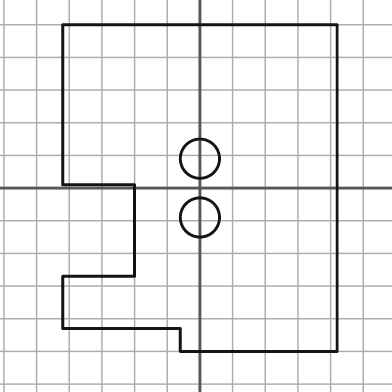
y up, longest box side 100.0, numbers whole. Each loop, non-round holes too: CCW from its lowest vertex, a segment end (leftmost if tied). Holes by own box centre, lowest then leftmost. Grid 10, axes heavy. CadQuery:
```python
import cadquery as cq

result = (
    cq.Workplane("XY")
    .moveTo(-6.0, -50.0)
    .lineTo(42.0, -50.0)
    .lineTo(42.0, 50.0)
    .lineTo(-42.0, 50.0)
    .lineTo(-42.0, 1.0)
    .lineTo(-20.0, 1.0)
    .lineTo(-20.0, -27.0)
    .lineTo(-42.0, -27.0)
    .lineTo(-42.0, -43.0)
    .lineTo(-6.0, -43.0)
    .close()
    .moveTo(0.0, -9.0)
    .circle(6.0)
    .moveTo(0.0, 9.0)
    .circle(6.0)
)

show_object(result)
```